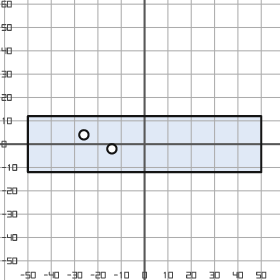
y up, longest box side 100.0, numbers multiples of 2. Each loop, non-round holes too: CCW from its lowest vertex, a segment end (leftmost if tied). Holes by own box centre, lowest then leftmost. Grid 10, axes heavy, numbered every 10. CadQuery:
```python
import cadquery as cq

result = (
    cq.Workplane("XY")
    .moveTo(-50.0, -12.0)
    .lineTo(50.0, -12.0)
    .lineTo(50.0, 12.0)
    .lineTo(-50.0, 12.0)
    .close()
    .moveTo(-14.0, -2.0)
    .circle(2.0)
    .moveTo(-26.0, 4.0)
    .circle(2.0)
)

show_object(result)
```